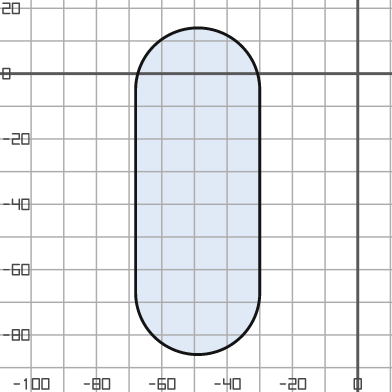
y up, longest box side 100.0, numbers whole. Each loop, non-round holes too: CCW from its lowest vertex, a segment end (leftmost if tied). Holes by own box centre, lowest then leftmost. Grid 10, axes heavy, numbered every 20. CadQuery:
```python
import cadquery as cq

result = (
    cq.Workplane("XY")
    .moveTo(-68.0, -67.0)
    .threePointArc((-49.0, -86.0), (-30.0, -67.0))
    .lineTo(-30.0, -5.0)
    .threePointArc((-49.0, 14.0), (-68.0, -5.0))
    .close()
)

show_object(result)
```